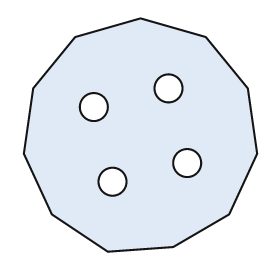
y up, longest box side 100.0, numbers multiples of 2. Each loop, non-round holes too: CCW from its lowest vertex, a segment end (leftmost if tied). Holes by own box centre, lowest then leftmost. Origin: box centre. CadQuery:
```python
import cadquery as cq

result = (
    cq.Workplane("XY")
    .moveTo(-14.0, -50.0)
    .lineTo(14.0, -48.0)
    .lineTo(38.0, -34.0)
    .lineTo(50.0, -8.0)
    .lineTo(46.0, 20.0)
    .lineTo(28.0, 42.0)
    .lineTo(0.0, 50.0)
    .lineTo(-28.0, 42.0)
    .lineTo(-46.0, 20.0)
    .lineTo(-50.0, -8.0)
    .lineTo(-38.0, -34.0)
    .close()
    .moveTo(-12.0, -20.0)
    .circle(6.0)
    .moveTo(20.0, -12.0)
    .circle(6.0)
    .moveTo(-20.0, 12.0)
    .circle(6.0)
    .moveTo(12.0, 20.0)
    .circle(6.0)
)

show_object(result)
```